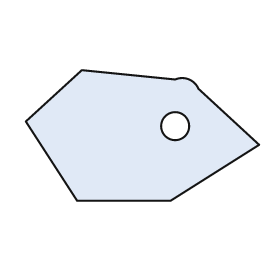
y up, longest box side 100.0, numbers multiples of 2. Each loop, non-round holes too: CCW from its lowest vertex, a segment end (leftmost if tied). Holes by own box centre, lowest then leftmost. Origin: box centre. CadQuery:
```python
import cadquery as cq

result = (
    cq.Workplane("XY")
    .moveTo(-28.0, -28.0)
    .lineTo(12.0, -28.0)
    .lineTo(50.0, -4.0)
    .lineTo(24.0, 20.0)
    .threePointArc((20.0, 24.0), (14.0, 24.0))
    .lineTo(-26.0, 28.0)
    .lineTo(-50.0, 6.0)
    .close()
    .moveTo(14.0, 4.0)
    .circle(6.0)
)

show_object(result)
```